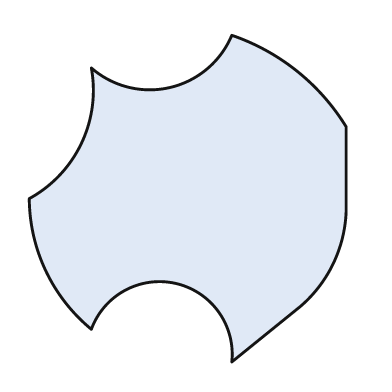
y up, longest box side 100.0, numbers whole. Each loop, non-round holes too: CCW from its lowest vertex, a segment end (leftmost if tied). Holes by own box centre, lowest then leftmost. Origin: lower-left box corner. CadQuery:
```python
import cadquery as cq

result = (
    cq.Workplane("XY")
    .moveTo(62.0, 0.0)
    .lineTo(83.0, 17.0)
    .threePointArc((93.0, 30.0), (97.0, 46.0))
    .lineTo(97.0, 72.0)
    .threePointArc((82.0, 89.0), (62.0, 100.0))
    .threePointArc((43.0, 84.0), (19.0, 90.0))
    .threePointArc((16.0, 67.0), (0.0, 50.0))
    .threePointArc((5.0, 28.0), (19.0, 10.0))
    .threePointArc((45.0, 24.0), (62.0, 0.0))
    .close()
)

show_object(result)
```